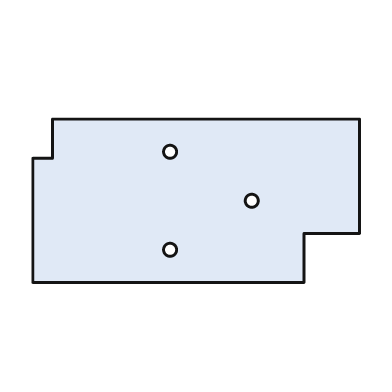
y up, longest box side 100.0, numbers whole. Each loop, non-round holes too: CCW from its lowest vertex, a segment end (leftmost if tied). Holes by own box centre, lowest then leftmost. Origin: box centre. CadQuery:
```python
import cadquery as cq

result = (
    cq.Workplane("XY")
    .moveTo(-50.0, -25.0)
    .lineTo(33.0, -25.0)
    .lineTo(33.0, -10.0)
    .lineTo(50.0, -10.0)
    .lineTo(50.0, 25.0)
    .lineTo(-44.0, 25.0)
    .lineTo(-44.0, 13.0)
    .lineTo(-50.0, 13.0)
    .close()
    .moveTo(-8.0, -15.0)
    .circle(2.0)
    .moveTo(17.0, 0.0)
    .circle(2.0)
    .moveTo(-8.0, 15.0)
    .circle(2.0)
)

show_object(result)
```